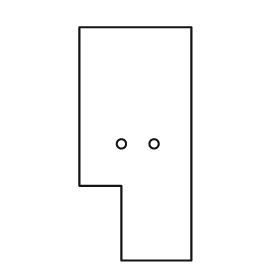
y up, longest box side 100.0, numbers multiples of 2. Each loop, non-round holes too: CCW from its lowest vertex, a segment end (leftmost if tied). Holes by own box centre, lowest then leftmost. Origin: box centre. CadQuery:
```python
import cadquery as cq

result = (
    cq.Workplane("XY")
    .moveTo(-6.0, -50.0)
    .lineTo(24.0, -50.0)
    .lineTo(24.0, 50.0)
    .lineTo(-24.0, 50.0)
    .lineTo(-24.0, -18.0)
    .lineTo(-6.0, -18.0)
    .close()
    .moveTo(-6.0, 0.0)
    .circle(2.0)
    .moveTo(8.0, 0.0)
    .circle(2.0)
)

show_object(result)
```